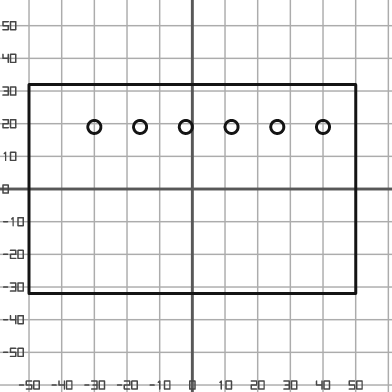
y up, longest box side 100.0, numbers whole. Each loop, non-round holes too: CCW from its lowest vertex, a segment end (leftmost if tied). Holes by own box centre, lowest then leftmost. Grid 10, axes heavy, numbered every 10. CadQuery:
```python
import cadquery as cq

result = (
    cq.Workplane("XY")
    .moveTo(-50.0, -32.0)
    .lineTo(50.0, -32.0)
    .lineTo(50.0, 32.0)
    .lineTo(-50.0, 32.0)
    .close()
    .moveTo(-30.0, 19.0)
    .circle(2.0)
    .moveTo(-16.0, 19.0)
    .circle(2.0)
    .moveTo(-2.0, 19.0)
    .circle(2.0)
    .moveTo(12.0, 19.0)
    .circle(2.0)
    .moveTo(26.0, 19.0)
    .circle(2.0)
    .moveTo(40.0, 19.0)
    .circle(2.0)
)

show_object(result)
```